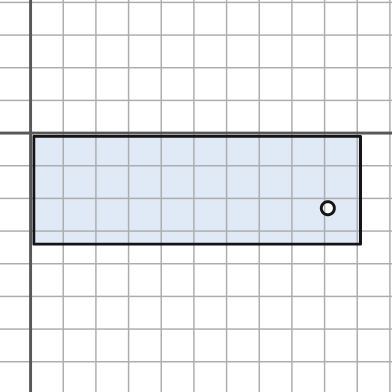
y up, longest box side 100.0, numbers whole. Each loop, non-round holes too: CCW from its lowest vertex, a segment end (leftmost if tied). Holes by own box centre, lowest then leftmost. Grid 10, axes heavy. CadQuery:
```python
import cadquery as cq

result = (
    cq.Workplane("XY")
    .moveTo(1.0, -34.0)
    .lineTo(101.0, -34.0)
    .lineTo(101.0, -1.0)
    .lineTo(1.0, -1.0)
    .close()
    .moveTo(91.0, -23.0)
    .circle(2.0)
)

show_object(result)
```